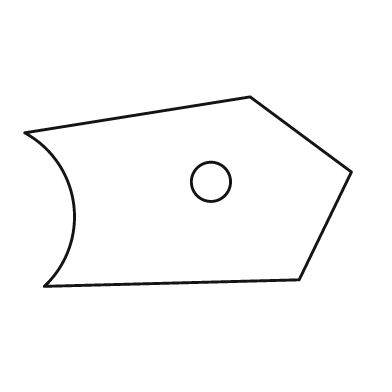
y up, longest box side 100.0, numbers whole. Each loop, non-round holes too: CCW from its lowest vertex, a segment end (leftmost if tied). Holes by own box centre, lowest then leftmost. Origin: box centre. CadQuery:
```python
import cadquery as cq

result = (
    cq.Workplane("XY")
    .moveTo(-44.0, -29.0)
    .lineTo(34.0, -27.0)
    .lineTo(50.0, 6.0)
    .lineTo(19.0, 29.0)
    .lineTo(-50.0, 18.0)
    .threePointArc((-35.0, -4.0), (-44.0, -29.0))
    .close()
    .moveTo(7.0, 3.0)
    .circle(6.0)
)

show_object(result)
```